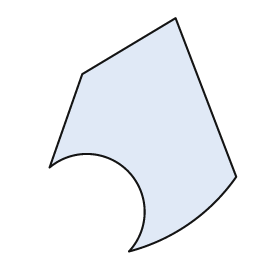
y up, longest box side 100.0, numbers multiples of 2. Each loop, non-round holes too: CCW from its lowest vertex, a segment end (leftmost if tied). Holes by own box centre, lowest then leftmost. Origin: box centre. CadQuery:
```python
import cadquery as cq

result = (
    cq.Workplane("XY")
    .moveTo(-6.0, -50.0)
    .threePointArc((20.0, -38.0), (40.0, -18.0))
    .lineTo(14.0, 50.0)
    .lineTo(-26.0, 26.0)
    .lineTo(-40.0, -14.0)
    .threePointArc((-6.0, -16.0), (-6.0, -50.0))
    .close()
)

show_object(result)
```